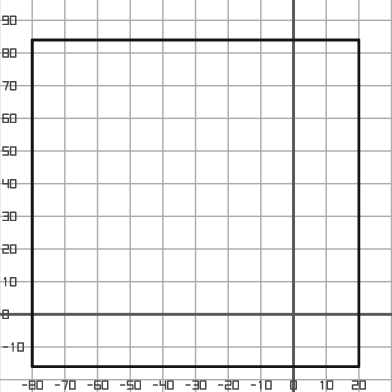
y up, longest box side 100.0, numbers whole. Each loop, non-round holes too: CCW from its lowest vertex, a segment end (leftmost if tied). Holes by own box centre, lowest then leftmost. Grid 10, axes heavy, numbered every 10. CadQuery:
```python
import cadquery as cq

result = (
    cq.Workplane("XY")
    .moveTo(-80.0, -16.0)
    .lineTo(20.0, -16.0)
    .lineTo(20.0, 84.0)
    .lineTo(-80.0, 84.0)
    .close()
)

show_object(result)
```